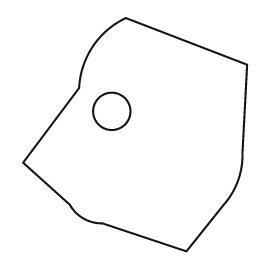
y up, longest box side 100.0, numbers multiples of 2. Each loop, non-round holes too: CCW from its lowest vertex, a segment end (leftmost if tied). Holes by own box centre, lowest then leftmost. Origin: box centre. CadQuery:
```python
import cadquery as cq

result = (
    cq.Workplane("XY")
    .moveTo(22.0, -50.0)
    .lineTo(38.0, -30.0)
    .threePointArc((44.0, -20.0), (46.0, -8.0))
    .lineTo(48.0, 30.0)
    .lineTo(-4.0, 50.0)
    .threePointArc((-18.0, 38.0), (-24.0, 20.0))
    .lineTo(-48.0, -12.0)
    .lineTo(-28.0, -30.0)
    .threePointArc((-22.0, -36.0), (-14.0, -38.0))
    .close()
    .moveTo(-10.0, 10.0)
    .circle(8.0)
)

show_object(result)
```